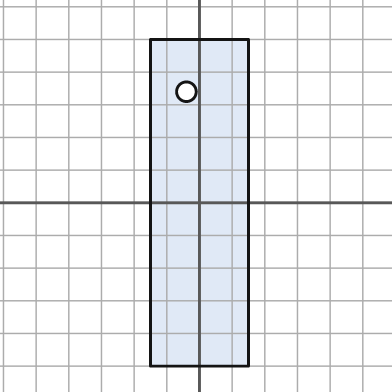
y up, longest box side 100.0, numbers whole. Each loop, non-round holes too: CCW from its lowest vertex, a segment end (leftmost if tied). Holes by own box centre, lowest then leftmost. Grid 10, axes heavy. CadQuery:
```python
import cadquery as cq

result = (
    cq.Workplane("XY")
    .moveTo(-15.0, -50.0)
    .lineTo(15.0, -50.0)
    .lineTo(15.0, 50.0)
    .lineTo(-15.0, 50.0)
    .close()
    .moveTo(-4.0, 34.0)
    .circle(3.0)
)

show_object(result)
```